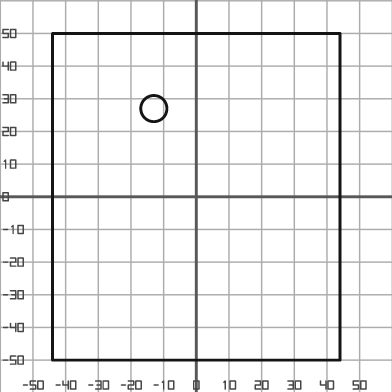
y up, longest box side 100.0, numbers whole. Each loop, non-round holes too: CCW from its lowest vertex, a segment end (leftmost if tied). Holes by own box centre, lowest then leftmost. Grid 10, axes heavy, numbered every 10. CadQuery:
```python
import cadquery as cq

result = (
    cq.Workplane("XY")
    .moveTo(-44.0, -50.0)
    .lineTo(44.0, -50.0)
    .lineTo(44.0, 50.0)
    .lineTo(-44.0, 50.0)
    .close()
    .moveTo(-13.0, 27.0)
    .circle(4.0)
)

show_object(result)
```